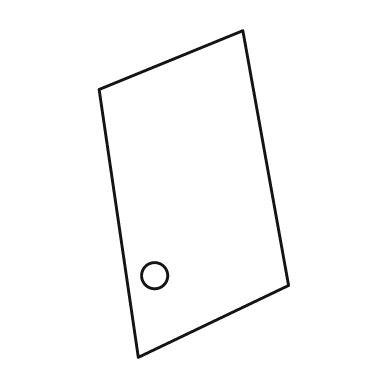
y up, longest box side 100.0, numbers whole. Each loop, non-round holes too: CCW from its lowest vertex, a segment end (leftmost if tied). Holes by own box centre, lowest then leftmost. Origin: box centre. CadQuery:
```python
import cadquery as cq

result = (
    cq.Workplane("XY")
    .moveTo(-17.0, -50.0)
    .lineTo(29.0, -28.0)
    .lineTo(15.0, 50.0)
    .lineTo(-29.0, 32.0)
    .close()
    .moveTo(-12.0, -25.0)
    .circle(4.0)
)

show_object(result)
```